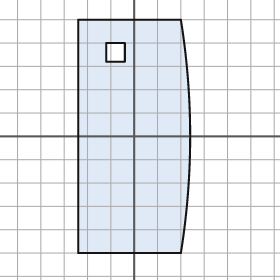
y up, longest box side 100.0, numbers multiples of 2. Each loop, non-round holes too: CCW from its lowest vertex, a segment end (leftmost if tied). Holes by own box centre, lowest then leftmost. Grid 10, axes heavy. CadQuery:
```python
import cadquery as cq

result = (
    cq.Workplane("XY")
    .moveTo(-24.0, -50.0)
    .lineTo(20.0, -50.0)
    .threePointArc((24.0, 0.0), (20.0, 50.0))
    .lineTo(-24.0, 50.0)
    .close()
    .moveTo(-12.0, 32.0)
    .lineTo(-4.0, 32.0)
    .lineTo(-4.0, 40.0)
    .lineTo(-12.0, 40.0)
    .close()
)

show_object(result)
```